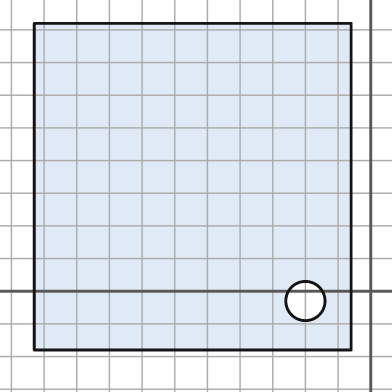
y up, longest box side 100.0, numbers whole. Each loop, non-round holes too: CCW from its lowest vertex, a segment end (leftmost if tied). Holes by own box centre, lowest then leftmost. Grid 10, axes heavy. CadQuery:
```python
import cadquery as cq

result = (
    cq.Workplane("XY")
    .moveTo(-103.0, -18.0)
    .lineTo(-6.0, -18.0)
    .lineTo(-6.0, 82.0)
    .lineTo(-103.0, 82.0)
    .close()
    .moveTo(-20.0, -3.0)
    .circle(6.0)
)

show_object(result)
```